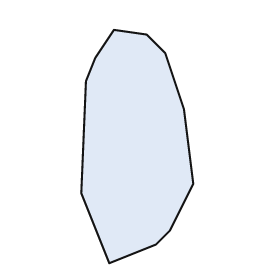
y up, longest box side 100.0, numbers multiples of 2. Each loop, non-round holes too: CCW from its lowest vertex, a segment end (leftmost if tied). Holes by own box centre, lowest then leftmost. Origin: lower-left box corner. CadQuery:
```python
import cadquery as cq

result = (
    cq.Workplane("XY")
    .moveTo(12.0, 0.0)
    .lineTo(32.0, 8.0)
    .lineTo(38.0, 14.0)
    .lineTo(48.0, 34.0)
    .lineTo(44.0, 66.0)
    .lineTo(36.0, 90.0)
    .lineTo(28.0, 98.0)
    .lineTo(14.0, 100.0)
    .lineTo(6.0, 88.0)
    .lineTo(2.0, 78.0)
    .lineTo(0.0, 30.0)
    .close()
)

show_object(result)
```